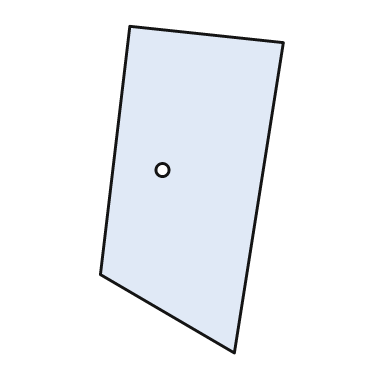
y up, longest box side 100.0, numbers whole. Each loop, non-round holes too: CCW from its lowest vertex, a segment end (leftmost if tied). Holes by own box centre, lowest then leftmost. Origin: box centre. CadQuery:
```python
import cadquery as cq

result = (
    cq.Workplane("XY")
    .moveTo(13.0, -50.0)
    .lineTo(28.0, 45.0)
    .lineTo(-19.0, 50.0)
    .lineTo(-28.0, -26.0)
    .close()
    .moveTo(-9.0, 6.0)
    .circle(2.0)
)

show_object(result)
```